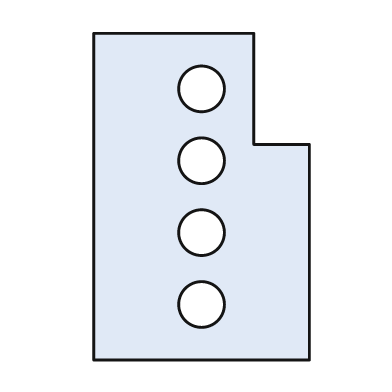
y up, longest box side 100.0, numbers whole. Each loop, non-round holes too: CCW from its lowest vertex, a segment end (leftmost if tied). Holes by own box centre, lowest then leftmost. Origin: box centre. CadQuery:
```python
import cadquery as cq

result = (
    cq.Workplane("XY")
    .moveTo(-33.0, -50.0)
    .lineTo(33.0, -50.0)
    .lineTo(33.0, 16.0)
    .lineTo(16.0, 16.0)
    .lineTo(16.0, 50.0)
    .lineTo(-33.0, 50.0)
    .close()
    .moveTo(0.0, -33.0)
    .circle(7.0)
    .moveTo(0.0, -11.0)
    .circle(7.0)
    .moveTo(0.0, 11.0)
    .circle(7.0)
    .moveTo(0.0, 33.0)
    .circle(7.0)
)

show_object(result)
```